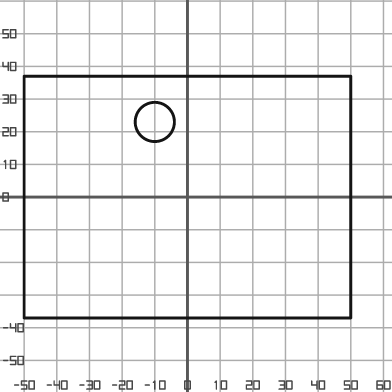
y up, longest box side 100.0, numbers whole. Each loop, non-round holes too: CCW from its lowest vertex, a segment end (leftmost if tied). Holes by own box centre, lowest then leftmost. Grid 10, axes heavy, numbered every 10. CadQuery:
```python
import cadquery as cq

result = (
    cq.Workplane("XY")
    .moveTo(-50.0, -37.0)
    .lineTo(50.0, -37.0)
    .lineTo(50.0, 37.0)
    .lineTo(-50.0, 37.0)
    .close()
    .moveTo(-10.0, 23.0)
    .circle(6.0)
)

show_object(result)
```